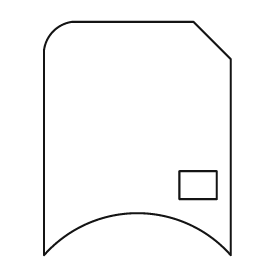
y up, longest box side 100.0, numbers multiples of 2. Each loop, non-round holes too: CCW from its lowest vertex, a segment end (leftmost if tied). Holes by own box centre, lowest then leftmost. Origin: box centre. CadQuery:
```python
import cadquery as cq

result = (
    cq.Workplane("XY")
    .moveTo(-40.0, -50.0)
    .threePointArc((0.0, -32.0), (40.0, -50.0))
    .lineTo(40.0, 34.0)
    .lineTo(24.0, 50.0)
    .lineTo(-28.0, 50.0)
    .threePointArc((-36.0, 46.0), (-40.0, 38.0))
    .close()
    .moveTo(18.0, -26.0)
    .lineTo(34.0, -26.0)
    .lineTo(34.0, -14.0)
    .lineTo(18.0, -14.0)
    .close()
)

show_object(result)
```